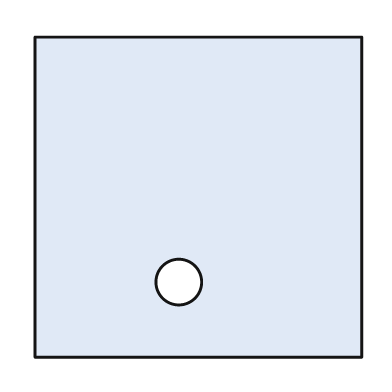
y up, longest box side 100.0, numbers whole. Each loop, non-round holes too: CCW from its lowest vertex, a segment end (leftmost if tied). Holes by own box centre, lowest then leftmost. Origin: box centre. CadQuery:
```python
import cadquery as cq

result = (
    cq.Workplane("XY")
    .moveTo(-50.0, -49.0)
    .lineTo(50.0, -49.0)
    .lineTo(50.0, 49.0)
    .lineTo(-50.0, 49.0)
    .close()
    .moveTo(-6.0, -26.0)
    .circle(7.0)
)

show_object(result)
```